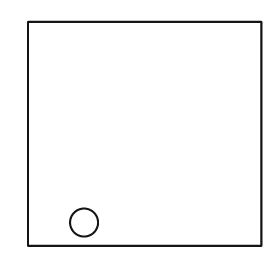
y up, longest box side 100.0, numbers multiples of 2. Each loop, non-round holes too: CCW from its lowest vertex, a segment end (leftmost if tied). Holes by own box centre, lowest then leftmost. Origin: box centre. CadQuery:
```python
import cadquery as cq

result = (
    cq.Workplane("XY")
    .moveTo(-50.0, -48.0)
    .lineTo(50.0, -48.0)
    .lineTo(50.0, 48.0)
    .lineTo(-50.0, 48.0)
    .close()
    .moveTo(-26.0, -38.0)
    .circle(6.0)
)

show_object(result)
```